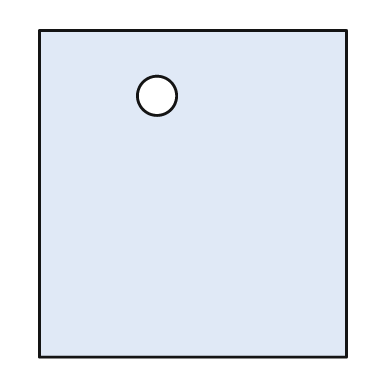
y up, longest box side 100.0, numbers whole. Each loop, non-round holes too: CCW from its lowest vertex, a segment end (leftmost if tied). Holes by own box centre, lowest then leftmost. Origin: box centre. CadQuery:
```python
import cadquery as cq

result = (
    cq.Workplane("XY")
    .moveTo(-47.0, -50.0)
    .lineTo(47.0, -50.0)
    .lineTo(47.0, 50.0)
    .lineTo(-47.0, 50.0)
    .close()
    .moveTo(-11.0, 30.0)
    .circle(6.0)
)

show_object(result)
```